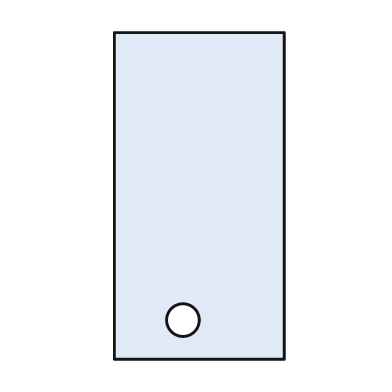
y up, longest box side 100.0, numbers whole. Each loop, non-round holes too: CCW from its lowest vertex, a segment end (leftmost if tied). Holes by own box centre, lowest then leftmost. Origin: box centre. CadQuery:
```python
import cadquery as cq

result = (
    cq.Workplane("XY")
    .moveTo(-26.0, -50.0)
    .lineTo(26.0, -50.0)
    .lineTo(26.0, 50.0)
    .lineTo(-26.0, 50.0)
    .close()
    .moveTo(-5.0, -38.0)
    .circle(5.0)
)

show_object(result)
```